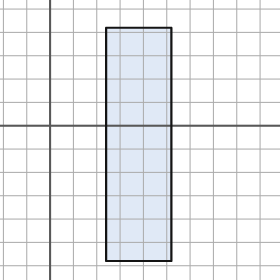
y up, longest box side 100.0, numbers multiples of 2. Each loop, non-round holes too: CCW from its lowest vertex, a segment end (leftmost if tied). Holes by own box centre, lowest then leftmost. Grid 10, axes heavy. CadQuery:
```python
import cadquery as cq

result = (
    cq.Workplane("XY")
    .moveTo(24.0, -58.0)
    .lineTo(52.0, -58.0)
    .lineTo(52.0, 42.0)
    .lineTo(24.0, 42.0)
    .close()
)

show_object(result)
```